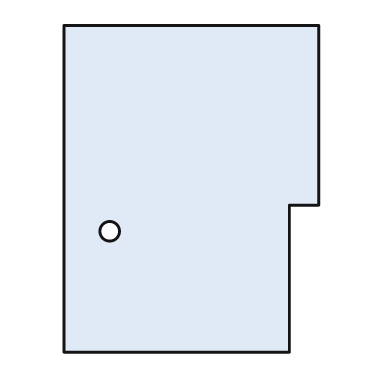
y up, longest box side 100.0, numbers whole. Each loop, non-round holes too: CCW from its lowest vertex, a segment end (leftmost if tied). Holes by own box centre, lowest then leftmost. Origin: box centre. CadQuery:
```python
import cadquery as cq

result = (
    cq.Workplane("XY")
    .moveTo(-39.0, -50.0)
    .lineTo(30.0, -50.0)
    .lineTo(30.0, -5.0)
    .lineTo(39.0, -5.0)
    .lineTo(39.0, 50.0)
    .lineTo(-39.0, 50.0)
    .close()
    .moveTo(-25.0, -13.0)
    .circle(3.0)
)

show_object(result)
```